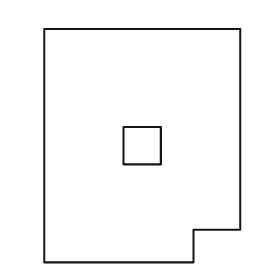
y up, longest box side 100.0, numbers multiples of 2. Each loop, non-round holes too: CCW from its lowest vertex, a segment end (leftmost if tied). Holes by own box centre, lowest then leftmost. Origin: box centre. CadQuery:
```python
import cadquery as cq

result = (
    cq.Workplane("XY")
    .moveTo(-42.0, -50.0)
    .lineTo(22.0, -50.0)
    .lineTo(22.0, -36.0)
    .lineTo(42.0, -36.0)
    .lineTo(42.0, 50.0)
    .lineTo(-42.0, 50.0)
    .close()
    .moveTo(-8.0, -8.0)
    .lineTo(8.0, -8.0)
    .lineTo(8.0, 8.0)
    .lineTo(-8.0, 8.0)
    .close()
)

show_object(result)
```